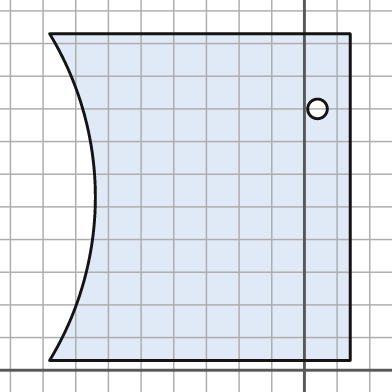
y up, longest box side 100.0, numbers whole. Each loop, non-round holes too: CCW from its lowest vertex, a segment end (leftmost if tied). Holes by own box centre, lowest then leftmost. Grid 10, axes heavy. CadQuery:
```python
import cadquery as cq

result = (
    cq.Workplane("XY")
    .moveTo(-78.0, 3.0)
    .lineTo(14.0, 3.0)
    .lineTo(14.0, 103.0)
    .lineTo(-78.0, 103.0)
    .threePointArc((-64.0, 53.0), (-78.0, 3.0))
    .close()
    .moveTo(4.0, 80.0)
    .circle(3.0)
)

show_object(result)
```